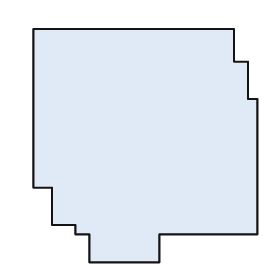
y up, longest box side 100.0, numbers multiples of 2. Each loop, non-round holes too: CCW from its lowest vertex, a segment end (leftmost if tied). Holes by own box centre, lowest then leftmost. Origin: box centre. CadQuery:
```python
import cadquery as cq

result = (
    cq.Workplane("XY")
    .moveTo(-24.0, -50.0)
    .lineTo(6.0, -50.0)
    .lineTo(6.0, -38.0)
    .lineTo(48.0, -38.0)
    .lineTo(48.0, 20.0)
    .lineTo(44.0, 20.0)
    .lineTo(44.0, 36.0)
    .lineTo(38.0, 36.0)
    .lineTo(38.0, 50.0)
    .lineTo(-48.0, 50.0)
    .lineTo(-48.0, -18.0)
    .lineTo(-40.0, -18.0)
    .lineTo(-40.0, -34.0)
    .lineTo(-30.0, -34.0)
    .lineTo(-30.0, -38.0)
    .lineTo(-24.0, -38.0)
    .close()
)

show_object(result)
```